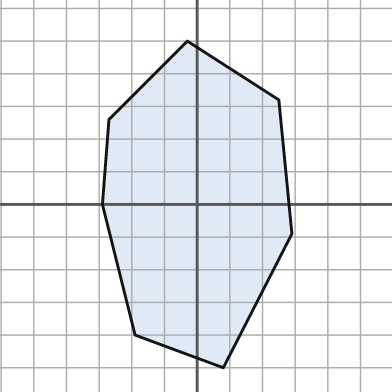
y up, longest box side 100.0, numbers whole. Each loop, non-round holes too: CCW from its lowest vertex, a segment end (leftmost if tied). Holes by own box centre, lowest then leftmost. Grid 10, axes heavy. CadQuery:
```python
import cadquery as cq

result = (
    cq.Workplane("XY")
    .moveTo(8.0, -50.0)
    .lineTo(29.0, -9.0)
    .lineTo(25.0, 32.0)
    .lineTo(-3.0, 50.0)
    .lineTo(-27.0, 26.0)
    .lineTo(-29.0, 0.0)
    .lineTo(-19.0, -40.0)
    .close()
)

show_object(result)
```